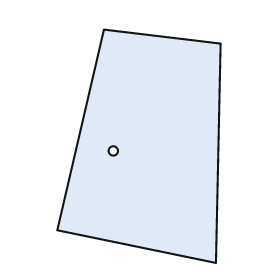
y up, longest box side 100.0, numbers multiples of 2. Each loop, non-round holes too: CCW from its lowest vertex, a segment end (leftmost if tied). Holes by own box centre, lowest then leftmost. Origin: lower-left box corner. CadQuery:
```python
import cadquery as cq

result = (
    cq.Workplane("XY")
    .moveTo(68.0, 0.0)
    .lineTo(70.0, 94.0)
    .lineTo(20.0, 100.0)
    .lineTo(0.0, 14.0)
    .close()
    .moveTo(24.0, 48.0)
    .circle(2.0)
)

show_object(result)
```